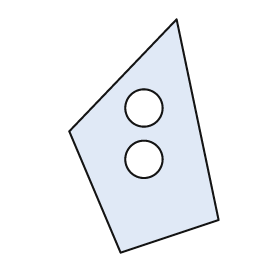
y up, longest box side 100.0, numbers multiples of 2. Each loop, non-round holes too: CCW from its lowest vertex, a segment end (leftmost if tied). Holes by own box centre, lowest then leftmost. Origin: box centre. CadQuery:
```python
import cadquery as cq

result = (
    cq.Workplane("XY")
    .moveTo(-10.0, -50.0)
    .lineTo(32.0, -36.0)
    .lineTo(14.0, 50.0)
    .lineTo(-32.0, 2.0)
    .close()
    .moveTo(0.0, -10.0)
    .circle(8.0)
    .moveTo(0.0, 12.0)
    .circle(8.0)
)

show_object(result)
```